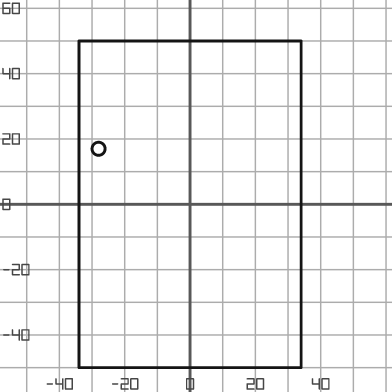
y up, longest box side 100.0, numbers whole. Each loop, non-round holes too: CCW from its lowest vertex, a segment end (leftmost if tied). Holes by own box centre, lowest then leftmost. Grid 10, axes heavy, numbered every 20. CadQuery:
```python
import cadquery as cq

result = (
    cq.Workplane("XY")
    .moveTo(-34.0, -50.0)
    .lineTo(34.0, -50.0)
    .lineTo(34.0, 50.0)
    .lineTo(-34.0, 50.0)
    .close()
    .moveTo(-28.0, 17.0)
    .circle(2.0)
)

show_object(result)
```